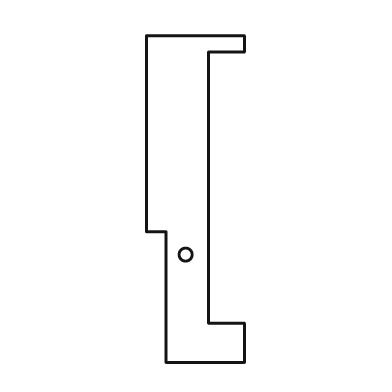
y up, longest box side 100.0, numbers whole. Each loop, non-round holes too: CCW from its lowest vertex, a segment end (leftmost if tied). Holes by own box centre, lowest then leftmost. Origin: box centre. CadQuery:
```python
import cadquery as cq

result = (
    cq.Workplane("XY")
    .moveTo(-9.0, -50.0)
    .lineTo(15.0, -50.0)
    .lineTo(15.0, -38.0)
    .lineTo(4.0, -38.0)
    .lineTo(4.0, 45.0)
    .lineTo(15.0, 45.0)
    .lineTo(15.0, 50.0)
    .lineTo(-15.0, 50.0)
    .lineTo(-15.0, -10.0)
    .lineTo(-9.0, -10.0)
    .close()
    .moveTo(-3.0, -17.0)
    .circle(2.0)
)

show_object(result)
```